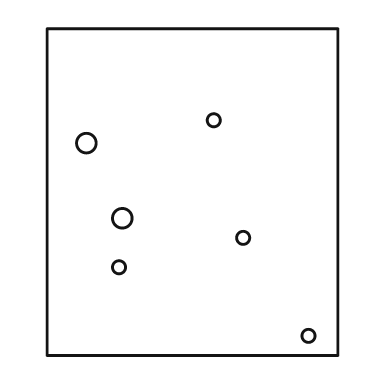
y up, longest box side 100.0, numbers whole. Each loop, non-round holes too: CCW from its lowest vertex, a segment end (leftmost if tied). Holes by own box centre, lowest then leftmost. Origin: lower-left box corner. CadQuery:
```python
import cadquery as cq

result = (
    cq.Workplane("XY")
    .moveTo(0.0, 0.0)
    .lineTo(89.0, 0.0)
    .lineTo(89.0, 100.0)
    .lineTo(0.0, 100.0)
    .close()
    .moveTo(80.0, 6.0)
    .circle(2.0)
    .moveTo(22.0, 27.0)
    .circle(2.0)
    .moveTo(60.0, 36.0)
    .circle(2.0)
    .moveTo(23.0, 42.0)
    .circle(3.0)
    .moveTo(12.0, 65.0)
    .circle(3.0)
    .moveTo(51.0, 72.0)
    .circle(2.0)
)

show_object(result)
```